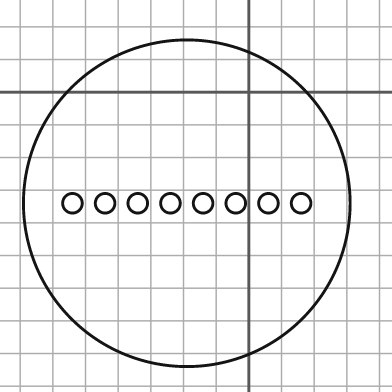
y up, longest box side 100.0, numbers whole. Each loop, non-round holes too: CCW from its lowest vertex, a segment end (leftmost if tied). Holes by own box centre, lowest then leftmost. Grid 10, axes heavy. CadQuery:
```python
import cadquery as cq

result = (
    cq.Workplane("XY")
    .moveTo(-19.0, -34.0)
    .circle(50.0)
    .moveTo(-54.0, -34.0)
    .circle(3.0)
    .moveTo(-44.0, -34.0)
    .circle(3.0)
    .moveTo(-34.0, -34.0)
    .circle(3.0)
    .moveTo(-24.0, -34.0)
    .circle(3.0)
    .moveTo(-14.0, -34.0)
    .circle(3.0)
    .moveTo(-4.0, -34.0)
    .circle(3.0)
    .moveTo(6.0, -34.0)
    .circle(3.0)
    .moveTo(16.0, -34.0)
    .circle(3.0)
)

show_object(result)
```